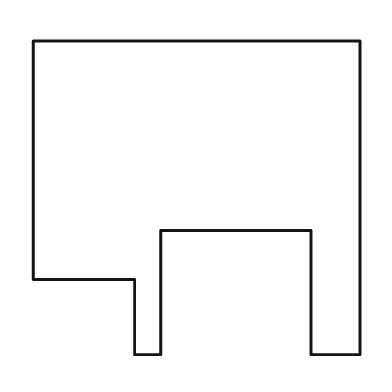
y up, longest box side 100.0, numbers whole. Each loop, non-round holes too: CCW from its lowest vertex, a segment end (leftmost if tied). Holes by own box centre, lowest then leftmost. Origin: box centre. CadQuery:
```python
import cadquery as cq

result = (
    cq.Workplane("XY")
    .moveTo(-19.0, -48.0)
    .lineTo(-11.0, -48.0)
    .lineTo(-11.0, -10.0)
    .lineTo(35.0, -10.0)
    .lineTo(35.0, -48.0)
    .lineTo(50.0, -48.0)
    .lineTo(50.0, 48.0)
    .lineTo(-50.0, 48.0)
    .lineTo(-50.0, -25.0)
    .lineTo(-19.0, -25.0)
    .close()
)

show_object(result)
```